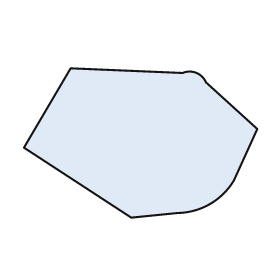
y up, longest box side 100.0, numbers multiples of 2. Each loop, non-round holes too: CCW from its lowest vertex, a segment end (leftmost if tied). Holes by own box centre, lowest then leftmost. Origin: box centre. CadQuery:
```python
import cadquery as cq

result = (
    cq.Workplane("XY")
    .moveTo(-4.0, -32.0)
    .lineTo(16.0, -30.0)
    .threePointArc((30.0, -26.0), (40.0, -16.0))
    .lineTo(50.0, 6.0)
    .lineTo(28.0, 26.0)
    .threePointArc((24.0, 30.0), (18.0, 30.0))
    .lineTo(-30.0, 32.0)
    .lineTo(-50.0, -2.0)
    .close()
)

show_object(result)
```